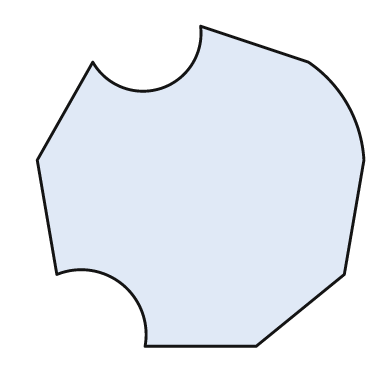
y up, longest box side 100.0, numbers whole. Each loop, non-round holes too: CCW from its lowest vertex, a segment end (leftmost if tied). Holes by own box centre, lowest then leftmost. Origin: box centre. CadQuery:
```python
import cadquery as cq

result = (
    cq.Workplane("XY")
    .moveTo(-17.0, -49.0)
    .lineTo(17.0, -49.0)
    .lineTo(44.0, -27.0)
    .lineTo(50.0, 8.0)
    .threePointArc((45.0, 25.0), (33.0, 38.0))
    .lineTo(0.0, 49.0)
    .threePointArc((-12.0, 30.0), (-33.0, 38.0))
    .lineTo(-50.0, 8.0)
    .lineTo(-44.0, -27.0)
    .threePointArc((-24.0, -30.0), (-17.0, -49.0))
    .close()
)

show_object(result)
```